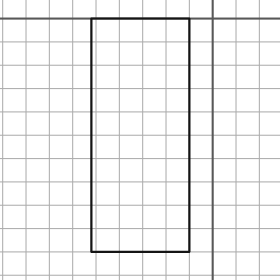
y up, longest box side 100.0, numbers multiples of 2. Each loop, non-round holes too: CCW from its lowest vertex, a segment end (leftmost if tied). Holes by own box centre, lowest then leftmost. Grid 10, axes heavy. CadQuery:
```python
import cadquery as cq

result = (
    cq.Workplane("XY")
    .moveTo(-52.0, -100.0)
    .lineTo(-10.0, -100.0)
    .lineTo(-10.0, 0.0)
    .lineTo(-52.0, 0.0)
    .close()
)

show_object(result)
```